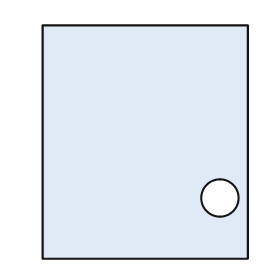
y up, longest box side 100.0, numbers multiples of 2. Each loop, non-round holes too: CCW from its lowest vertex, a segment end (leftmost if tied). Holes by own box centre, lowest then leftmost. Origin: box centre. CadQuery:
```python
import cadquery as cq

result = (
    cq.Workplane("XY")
    .moveTo(-44.0, -50.0)
    .lineTo(44.0, -50.0)
    .lineTo(44.0, 50.0)
    .lineTo(-44.0, 50.0)
    .close()
    .moveTo(32.0, -24.0)
    .circle(8.0)
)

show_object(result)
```